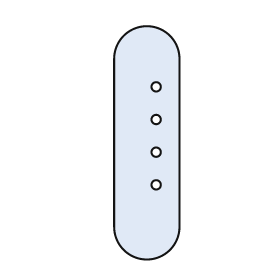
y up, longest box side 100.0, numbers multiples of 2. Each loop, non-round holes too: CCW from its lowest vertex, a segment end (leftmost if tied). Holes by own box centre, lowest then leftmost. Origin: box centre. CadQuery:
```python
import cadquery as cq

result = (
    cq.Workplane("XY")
    .moveTo(-14.0, -36.0)
    .threePointArc((0.0, -50.0), (14.0, -36.0))
    .lineTo(14.0, 36.0)
    .threePointArc((0.0, 50.0), (-14.0, 36.0))
    .close()
    .moveTo(4.0, -18.0)
    .circle(2.0)
    .moveTo(4.0, -4.0)
    .circle(2.0)
    .moveTo(4.0, 10.0)
    .circle(2.0)
    .moveTo(4.0, 24.0)
    .circle(2.0)
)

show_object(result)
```